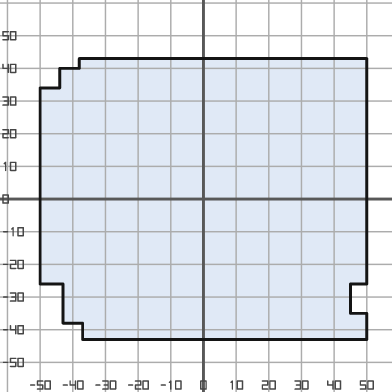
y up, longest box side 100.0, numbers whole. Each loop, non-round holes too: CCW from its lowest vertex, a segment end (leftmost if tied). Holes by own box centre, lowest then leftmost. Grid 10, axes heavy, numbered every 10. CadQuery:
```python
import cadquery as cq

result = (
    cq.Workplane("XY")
    .moveTo(-37.0, -43.0)
    .lineTo(50.0, -43.0)
    .lineTo(50.0, -35.0)
    .lineTo(45.0, -35.0)
    .lineTo(45.0, -26.0)
    .lineTo(50.0, -26.0)
    .lineTo(50.0, 43.0)
    .lineTo(-38.0, 43.0)
    .lineTo(-38.0, 40.0)
    .lineTo(-44.0, 40.0)
    .lineTo(-44.0, 34.0)
    .lineTo(-50.0, 34.0)
    .lineTo(-50.0, -26.0)
    .lineTo(-43.0, -26.0)
    .lineTo(-43.0, -38.0)
    .lineTo(-37.0, -38.0)
    .close()
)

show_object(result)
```